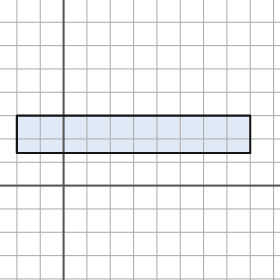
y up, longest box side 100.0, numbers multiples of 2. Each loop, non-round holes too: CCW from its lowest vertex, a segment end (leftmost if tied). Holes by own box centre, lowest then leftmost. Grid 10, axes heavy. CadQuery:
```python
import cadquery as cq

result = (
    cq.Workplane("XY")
    .moveTo(-20.0, 14.0)
    .lineTo(80.0, 14.0)
    .lineTo(80.0, 30.0)
    .lineTo(-20.0, 30.0)
    .close()
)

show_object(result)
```